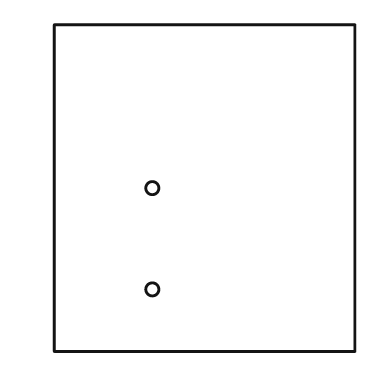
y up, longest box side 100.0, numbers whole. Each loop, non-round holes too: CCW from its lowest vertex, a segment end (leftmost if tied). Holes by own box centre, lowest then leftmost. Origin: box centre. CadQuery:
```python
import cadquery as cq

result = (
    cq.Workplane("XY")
    .moveTo(-46.0, -50.0)
    .lineTo(46.0, -50.0)
    .lineTo(46.0, 50.0)
    .lineTo(-46.0, 50.0)
    .close()
    .moveTo(-16.0, -31.0)
    .circle(2.0)
    .moveTo(-16.0, 0.0)
    .circle(2.0)
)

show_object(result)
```